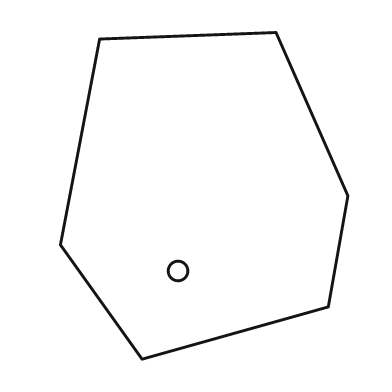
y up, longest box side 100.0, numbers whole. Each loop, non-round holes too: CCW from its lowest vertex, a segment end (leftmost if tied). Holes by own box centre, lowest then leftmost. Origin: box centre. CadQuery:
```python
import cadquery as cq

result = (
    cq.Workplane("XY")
    .moveTo(-19.0, -50.0)
    .lineTo(38.0, -34.0)
    .lineTo(44.0, 0.0)
    .lineTo(22.0, 50.0)
    .lineTo(-32.0, 48.0)
    .lineTo(-44.0, -15.0)
    .close()
    .moveTo(-8.0, -23.0)
    .circle(3.0)
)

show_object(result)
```